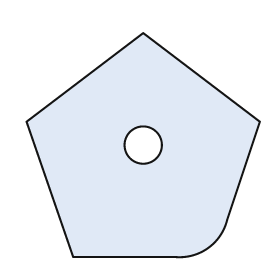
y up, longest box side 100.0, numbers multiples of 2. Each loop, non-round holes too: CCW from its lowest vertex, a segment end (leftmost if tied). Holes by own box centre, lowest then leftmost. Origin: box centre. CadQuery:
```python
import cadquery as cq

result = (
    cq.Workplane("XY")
    .moveTo(-30.0, -48.0)
    .lineTo(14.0, -48.0)
    .threePointArc((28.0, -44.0), (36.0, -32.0))
    .lineTo(50.0, 10.0)
    .lineTo(0.0, 48.0)
    .lineTo(-50.0, 10.0)
    .close()
    .moveTo(0.0, 0.0)
    .circle(8.0)
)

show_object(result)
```